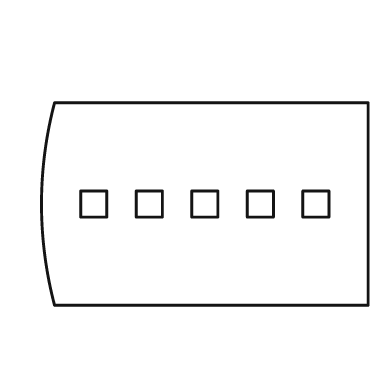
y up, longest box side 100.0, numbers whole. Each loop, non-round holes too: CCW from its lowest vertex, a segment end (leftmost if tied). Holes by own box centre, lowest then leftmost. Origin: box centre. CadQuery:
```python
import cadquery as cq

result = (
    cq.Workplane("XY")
    .moveTo(-46.0, -31.0)
    .lineTo(50.0, -31.0)
    .lineTo(50.0, 31.0)
    .lineTo(-46.0, 31.0)
    .threePointArc((-50.0, 0.0), (-46.0, -31.0))
    .close()
    .moveTo(-38.0, -4.0)
    .lineTo(-30.0, -4.0)
    .lineTo(-30.0, 4.0)
    .lineTo(-38.0, 4.0)
    .close()
    .moveTo(-21.0, -4.0)
    .lineTo(-13.0, -4.0)
    .lineTo(-13.0, 4.0)
    .lineTo(-21.0, 4.0)
    .close()
    .moveTo(-4.0, -4.0)
    .lineTo(4.0, -4.0)
    .lineTo(4.0, 4.0)
    .lineTo(-4.0, 4.0)
    .close()
    .moveTo(13.0, -4.0)
    .lineTo(21.0, -4.0)
    .lineTo(21.0, 4.0)
    .lineTo(13.0, 4.0)
    .close()
    .moveTo(30.0, -4.0)
    .lineTo(38.0, -4.0)
    .lineTo(38.0, 4.0)
    .lineTo(30.0, 4.0)
    .close()
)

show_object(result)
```